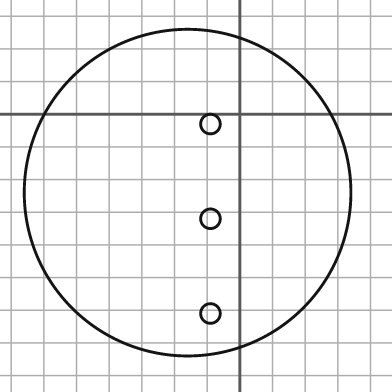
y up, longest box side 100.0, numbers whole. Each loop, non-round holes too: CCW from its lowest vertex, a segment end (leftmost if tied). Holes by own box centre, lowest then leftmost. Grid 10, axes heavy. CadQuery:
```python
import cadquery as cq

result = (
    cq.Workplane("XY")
    .moveTo(-16.0, -24.0)
    .circle(50.0)
    .moveTo(-9.0, -61.0)
    .circle(3.0)
    .moveTo(-9.0, -32.0)
    .circle(3.0)
    .moveTo(-9.0, -3.0)
    .circle(3.0)
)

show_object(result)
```